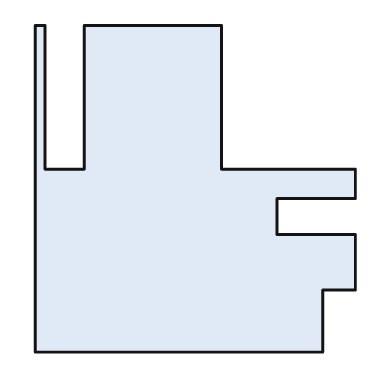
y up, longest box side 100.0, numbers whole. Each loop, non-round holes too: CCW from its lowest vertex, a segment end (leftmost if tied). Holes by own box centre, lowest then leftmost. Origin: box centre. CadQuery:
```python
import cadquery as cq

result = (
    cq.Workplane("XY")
    .moveTo(-49.0, -50.0)
    .lineTo(39.0, -50.0)
    .lineTo(39.0, -31.0)
    .lineTo(49.0, -31.0)
    .lineTo(49.0, -14.0)
    .lineTo(25.0, -14.0)
    .lineTo(25.0, -3.0)
    .lineTo(49.0, -3.0)
    .lineTo(49.0, 6.0)
    .lineTo(8.0, 6.0)
    .lineTo(8.0, 50.0)
    .lineTo(-34.0, 50.0)
    .lineTo(-34.0, 6.0)
    .lineTo(-46.0, 6.0)
    .lineTo(-46.0, 50.0)
    .lineTo(-49.0, 50.0)
    .close()
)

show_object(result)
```